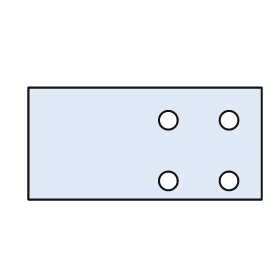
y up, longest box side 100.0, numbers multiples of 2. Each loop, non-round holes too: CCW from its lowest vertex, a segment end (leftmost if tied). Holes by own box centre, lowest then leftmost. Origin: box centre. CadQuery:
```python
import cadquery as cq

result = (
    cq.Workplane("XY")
    .moveTo(-50.0, -24.0)
    .lineTo(50.0, -24.0)
    .lineTo(50.0, 24.0)
    .lineTo(-50.0, 24.0)
    .close()
    .moveTo(10.0, -16.0)
    .circle(4.0)
    .moveTo(36.0, -16.0)
    .circle(4.0)
    .moveTo(10.0, 10.0)
    .circle(4.0)
    .moveTo(36.0, 10.0)
    .circle(4.0)
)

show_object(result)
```